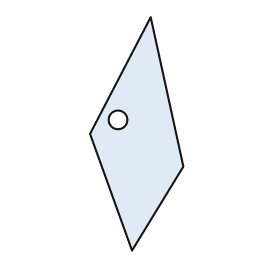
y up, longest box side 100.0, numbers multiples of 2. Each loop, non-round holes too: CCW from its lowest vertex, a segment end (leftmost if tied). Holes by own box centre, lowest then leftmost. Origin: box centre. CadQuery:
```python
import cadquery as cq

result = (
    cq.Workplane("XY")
    .moveTo(-2.0, -50.0)
    .lineTo(20.0, -14.0)
    .lineTo(6.0, 50.0)
    .lineTo(-20.0, 0.0)
    .close()
    .moveTo(-8.0, 6.0)
    .circle(4.0)
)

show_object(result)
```